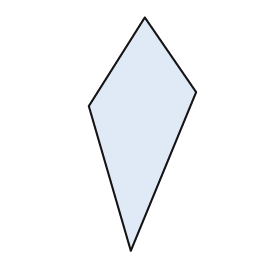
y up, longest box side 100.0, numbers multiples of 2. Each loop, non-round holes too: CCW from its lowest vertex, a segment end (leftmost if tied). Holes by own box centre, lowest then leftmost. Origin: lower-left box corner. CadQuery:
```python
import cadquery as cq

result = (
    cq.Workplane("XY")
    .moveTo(18.0, 0.0)
    .lineTo(46.0, 68.0)
    .lineTo(24.0, 100.0)
    .lineTo(0.0, 62.0)
    .close()
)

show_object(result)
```